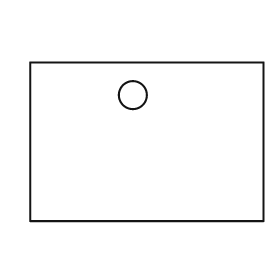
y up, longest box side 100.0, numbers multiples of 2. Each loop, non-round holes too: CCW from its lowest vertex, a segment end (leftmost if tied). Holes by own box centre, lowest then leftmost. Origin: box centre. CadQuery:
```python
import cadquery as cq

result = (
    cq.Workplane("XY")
    .moveTo(-50.0, -34.0)
    .lineTo(50.0, -34.0)
    .lineTo(50.0, 34.0)
    .lineTo(-50.0, 34.0)
    .close()
    .moveTo(-6.0, 20.0)
    .circle(6.0)
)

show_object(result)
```